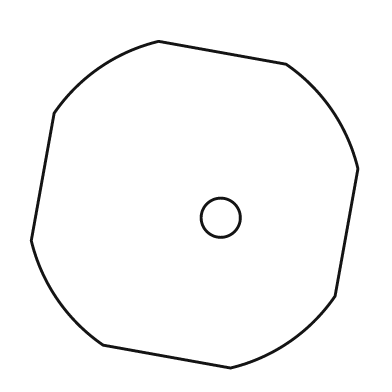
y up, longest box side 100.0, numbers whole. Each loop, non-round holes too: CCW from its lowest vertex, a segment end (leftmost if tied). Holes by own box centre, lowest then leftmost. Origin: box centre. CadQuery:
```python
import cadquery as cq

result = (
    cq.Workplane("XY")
    .moveTo(11.0, -50.0)
    .threePointArc((29.0, -42.0), (43.0, -28.0))
    .lineTo(50.0, 11.0)
    .threePointArc((42.0, 29.0), (28.0, 43.0))
    .lineTo(-11.0, 50.0)
    .threePointArc((-29.0, 42.0), (-43.0, 28.0))
    .lineTo(-50.0, -11.0)
    .threePointArc((-42.0, -29.0), (-28.0, -43.0))
    .close()
    .moveTo(8.0, -4.0)
    .circle(6.0)
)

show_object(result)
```